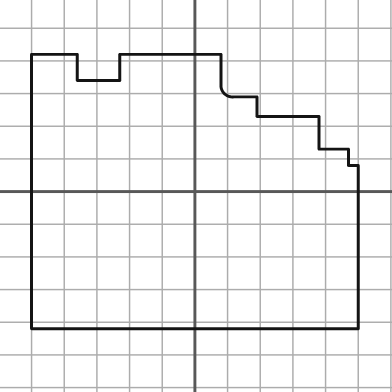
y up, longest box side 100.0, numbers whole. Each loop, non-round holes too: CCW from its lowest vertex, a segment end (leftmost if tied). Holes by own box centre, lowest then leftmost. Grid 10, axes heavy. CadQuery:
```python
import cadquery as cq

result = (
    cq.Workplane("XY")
    .moveTo(-50.0, -42.0)
    .lineTo(50.0, -42.0)
    .lineTo(50.0, 8.0)
    .lineTo(47.0, 8.0)
    .lineTo(47.0, 13.0)
    .lineTo(38.0, 13.0)
    .lineTo(38.0, 23.0)
    .lineTo(19.0, 23.0)
    .lineTo(19.0, 29.0)
    .lineTo(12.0, 29.0)
    .threePointArc((9.0, 30.0), (8.0, 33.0))
    .lineTo(8.0, 42.0)
    .lineTo(-23.0, 42.0)
    .lineTo(-23.0, 34.0)
    .lineTo(-36.0, 34.0)
    .lineTo(-36.0, 42.0)
    .lineTo(-50.0, 42.0)
    .close()
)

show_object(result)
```